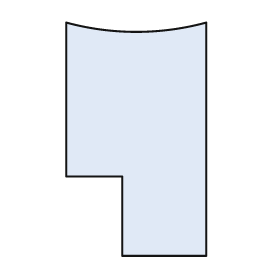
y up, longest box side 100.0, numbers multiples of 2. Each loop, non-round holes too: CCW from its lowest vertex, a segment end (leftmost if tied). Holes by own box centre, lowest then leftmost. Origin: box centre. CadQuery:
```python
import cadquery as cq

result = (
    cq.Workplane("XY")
    .moveTo(-6.0, -50.0)
    .lineTo(30.0, -50.0)
    .lineTo(30.0, 50.0)
    .threePointArc((0.0, 46.0), (-30.0, 50.0))
    .lineTo(-30.0, -16.0)
    .lineTo(-6.0, -16.0)
    .close()
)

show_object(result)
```